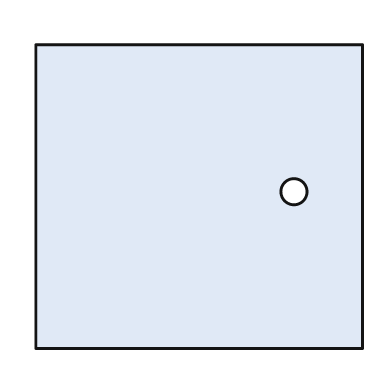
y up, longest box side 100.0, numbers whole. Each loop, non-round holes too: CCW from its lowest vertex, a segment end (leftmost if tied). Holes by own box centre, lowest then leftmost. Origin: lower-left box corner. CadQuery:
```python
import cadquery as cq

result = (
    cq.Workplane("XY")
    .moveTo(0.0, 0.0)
    .lineTo(100.0, 0.0)
    .lineTo(100.0, 93.0)
    .lineTo(0.0, 93.0)
    .close()
    .moveTo(79.0, 48.0)
    .circle(4.0)
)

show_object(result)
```